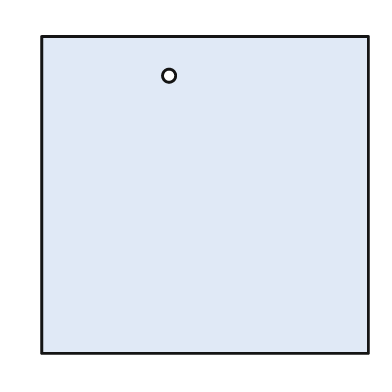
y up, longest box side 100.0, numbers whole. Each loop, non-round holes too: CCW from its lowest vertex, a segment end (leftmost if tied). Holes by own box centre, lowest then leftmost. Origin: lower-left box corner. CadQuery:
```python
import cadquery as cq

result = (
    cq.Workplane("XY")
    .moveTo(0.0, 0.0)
    .lineTo(100.0, 0.0)
    .lineTo(100.0, 97.0)
    .lineTo(0.0, 97.0)
    .close()
    .moveTo(39.0, 85.0)
    .circle(2.0)
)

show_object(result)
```